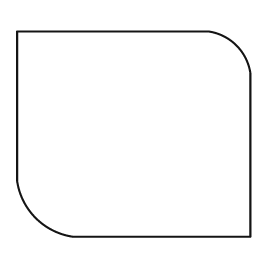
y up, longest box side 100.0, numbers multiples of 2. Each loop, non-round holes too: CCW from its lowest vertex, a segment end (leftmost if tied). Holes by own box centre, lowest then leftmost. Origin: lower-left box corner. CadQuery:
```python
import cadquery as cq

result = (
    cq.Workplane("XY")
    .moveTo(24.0, 0.0)
    .lineTo(100.0, 0.0)
    .lineTo(100.0, 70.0)
    .threePointArc((94.0, 82.0), (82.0, 88.0))
    .lineTo(0.0, 88.0)
    .lineTo(0.0, 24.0)
    .threePointArc((8.0, 8.0), (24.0, 0.0))
    .close()
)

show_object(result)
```